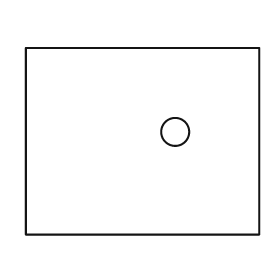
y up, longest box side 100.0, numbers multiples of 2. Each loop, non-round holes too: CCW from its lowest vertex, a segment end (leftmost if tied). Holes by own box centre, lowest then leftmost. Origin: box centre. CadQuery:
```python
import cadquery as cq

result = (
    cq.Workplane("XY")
    .moveTo(-50.0, -40.0)
    .lineTo(50.0, -40.0)
    .lineTo(50.0, 40.0)
    .lineTo(-50.0, 40.0)
    .close()
    .moveTo(14.0, 4.0)
    .circle(6.0)
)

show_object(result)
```